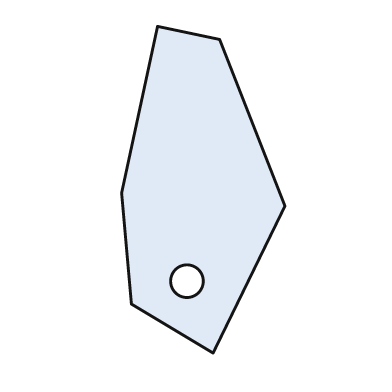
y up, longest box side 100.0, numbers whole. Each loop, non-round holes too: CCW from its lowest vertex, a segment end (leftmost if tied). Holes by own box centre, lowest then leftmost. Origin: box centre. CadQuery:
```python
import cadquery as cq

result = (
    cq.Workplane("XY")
    .moveTo(3.0, -50.0)
    .lineTo(25.0, -5.0)
    .lineTo(5.0, 46.0)
    .lineTo(-14.0, 50.0)
    .lineTo(-25.0, -1.0)
    .lineTo(-22.0, -35.0)
    .close()
    .moveTo(-5.0, -28.0)
    .circle(5.0)
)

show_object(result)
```